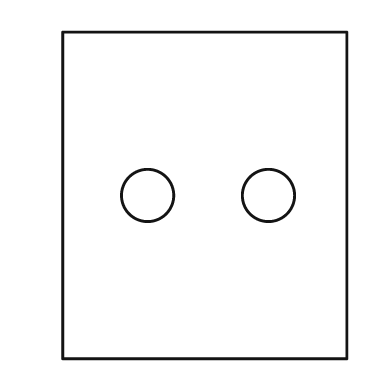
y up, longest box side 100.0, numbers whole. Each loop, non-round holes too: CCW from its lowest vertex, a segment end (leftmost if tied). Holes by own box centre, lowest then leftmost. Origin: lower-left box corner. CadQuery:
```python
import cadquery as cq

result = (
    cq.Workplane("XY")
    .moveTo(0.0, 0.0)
    .lineTo(87.0, 0.0)
    .lineTo(87.0, 100.0)
    .lineTo(0.0, 100.0)
    .close()
    .moveTo(26.0, 50.0)
    .circle(8.0)
    .moveTo(63.0, 50.0)
    .circle(8.0)
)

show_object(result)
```